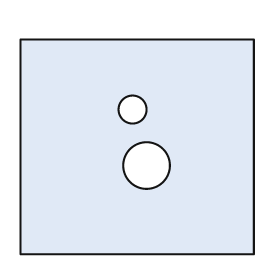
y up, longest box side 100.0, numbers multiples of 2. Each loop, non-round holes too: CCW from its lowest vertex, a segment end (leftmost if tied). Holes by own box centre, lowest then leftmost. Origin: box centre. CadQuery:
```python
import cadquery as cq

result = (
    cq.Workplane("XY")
    .moveTo(-50.0, -46.0)
    .lineTo(50.0, -46.0)
    .lineTo(50.0, 46.0)
    .lineTo(-50.0, 46.0)
    .close()
    .moveTo(4.0, -8.0)
    .circle(10.0)
    .moveTo(-2.0, 16.0)
    .circle(6.0)
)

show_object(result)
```